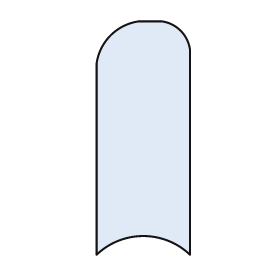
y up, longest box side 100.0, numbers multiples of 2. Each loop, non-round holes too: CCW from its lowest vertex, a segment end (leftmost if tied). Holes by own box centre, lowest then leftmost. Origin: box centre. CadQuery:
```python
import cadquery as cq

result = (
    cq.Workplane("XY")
    .moveTo(-20.0, -50.0)
    .threePointArc((0.0, -42.0), (20.0, -50.0))
    .lineTo(20.0, 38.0)
    .threePointArc((16.0, 46.0), (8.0, 50.0))
    .lineTo(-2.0, 50.0)
    .threePointArc((-14.0, 44.0), (-20.0, 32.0))
    .close()
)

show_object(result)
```